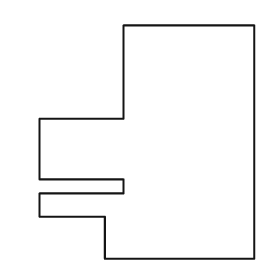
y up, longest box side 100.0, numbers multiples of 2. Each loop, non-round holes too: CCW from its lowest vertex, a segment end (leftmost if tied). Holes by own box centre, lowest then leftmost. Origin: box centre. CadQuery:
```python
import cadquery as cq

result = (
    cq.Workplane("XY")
    .moveTo(-18.0, -50.0)
    .lineTo(46.0, -50.0)
    .lineTo(46.0, 50.0)
    .lineTo(-10.0, 50.0)
    .lineTo(-10.0, 10.0)
    .lineTo(-46.0, 10.0)
    .lineTo(-46.0, -16.0)
    .lineTo(-10.0, -16.0)
    .lineTo(-10.0, -22.0)
    .lineTo(-46.0, -22.0)
    .lineTo(-46.0, -32.0)
    .lineTo(-18.0, -32.0)
    .close()
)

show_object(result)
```